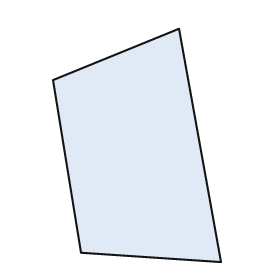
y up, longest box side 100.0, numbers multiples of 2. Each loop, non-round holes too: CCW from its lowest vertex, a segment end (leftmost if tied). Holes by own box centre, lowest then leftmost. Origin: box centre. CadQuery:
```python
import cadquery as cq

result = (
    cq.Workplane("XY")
    .moveTo(36.0, -50.0)
    .lineTo(18.0, 50.0)
    .lineTo(-36.0, 28.0)
    .lineTo(-24.0, -46.0)
    .close()
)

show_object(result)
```